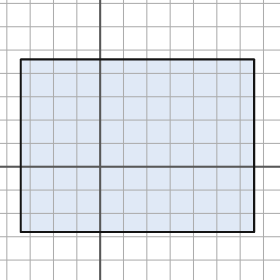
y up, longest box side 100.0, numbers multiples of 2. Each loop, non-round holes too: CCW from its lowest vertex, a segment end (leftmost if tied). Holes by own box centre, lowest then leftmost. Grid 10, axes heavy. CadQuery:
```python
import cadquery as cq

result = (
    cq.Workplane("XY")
    .moveTo(-34.0, -28.0)
    .lineTo(66.0, -28.0)
    .lineTo(66.0, 46.0)
    .lineTo(-34.0, 46.0)
    .close()
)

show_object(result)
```